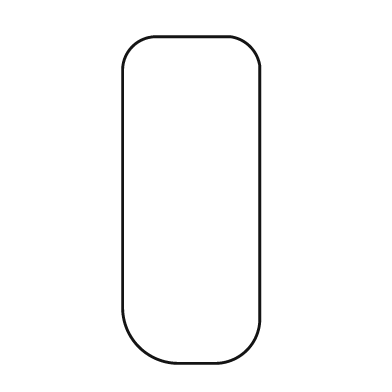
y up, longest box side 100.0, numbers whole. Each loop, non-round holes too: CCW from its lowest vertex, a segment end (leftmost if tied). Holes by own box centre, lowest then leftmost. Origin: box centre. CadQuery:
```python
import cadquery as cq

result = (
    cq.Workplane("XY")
    .moveTo(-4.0, -50.0)
    .lineTo(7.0, -50.0)
    .threePointArc((17.0, -46.0), (21.0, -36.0))
    .lineTo(21.0, 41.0)
    .threePointArc((18.0, 47.0), (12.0, 50.0))
    .lineTo(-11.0, 50.0)
    .threePointArc((-18.0, 47.0), (-21.0, 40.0))
    .lineTo(-21.0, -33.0)
    .threePointArc((-16.0, -45.0), (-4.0, -50.0))
    .close()
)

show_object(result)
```